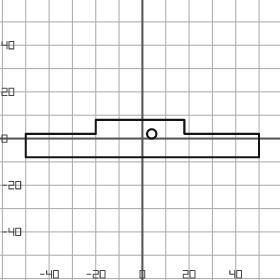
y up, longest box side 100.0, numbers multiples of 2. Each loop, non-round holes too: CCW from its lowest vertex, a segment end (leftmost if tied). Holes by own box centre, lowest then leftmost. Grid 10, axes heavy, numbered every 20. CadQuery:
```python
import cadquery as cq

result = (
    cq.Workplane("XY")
    .moveTo(-50.0, -8.0)
    .lineTo(50.0, -8.0)
    .lineTo(50.0, 2.0)
    .lineTo(18.0, 2.0)
    .lineTo(18.0, 8.0)
    .lineTo(-20.0, 8.0)
    .lineTo(-20.0, 2.0)
    .lineTo(-50.0, 2.0)
    .close()
    .moveTo(4.0, 2.0)
    .circle(2.0)
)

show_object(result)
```